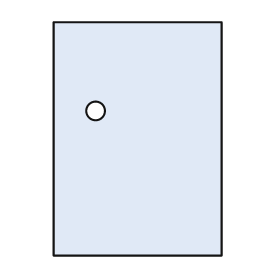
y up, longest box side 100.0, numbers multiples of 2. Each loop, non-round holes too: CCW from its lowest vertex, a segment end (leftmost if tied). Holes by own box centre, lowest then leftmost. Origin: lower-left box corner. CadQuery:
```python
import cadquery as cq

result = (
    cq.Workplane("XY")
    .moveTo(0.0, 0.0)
    .lineTo(72.0, 0.0)
    .lineTo(72.0, 100.0)
    .lineTo(0.0, 100.0)
    .close()
    .moveTo(18.0, 62.0)
    .circle(4.0)
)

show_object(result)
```